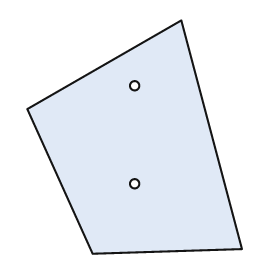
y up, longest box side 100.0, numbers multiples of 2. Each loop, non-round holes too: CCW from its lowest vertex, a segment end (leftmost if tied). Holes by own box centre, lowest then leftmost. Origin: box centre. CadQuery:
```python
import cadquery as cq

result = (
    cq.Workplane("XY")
    .moveTo(-18.0, -50.0)
    .lineTo(46.0, -48.0)
    .lineTo(20.0, 50.0)
    .lineTo(-46.0, 12.0)
    .close()
    .moveTo(0.0, -20.0)
    .circle(2.0)
    .moveTo(0.0, 22.0)
    .circle(2.0)
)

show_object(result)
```